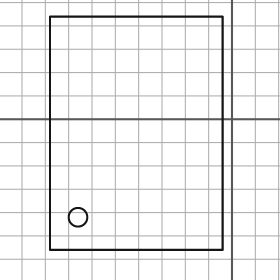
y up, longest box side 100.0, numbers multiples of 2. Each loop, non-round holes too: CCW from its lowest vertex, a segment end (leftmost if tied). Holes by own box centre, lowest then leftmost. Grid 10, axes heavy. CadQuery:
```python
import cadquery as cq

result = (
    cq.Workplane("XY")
    .moveTo(-78.0, -56.0)
    .lineTo(-4.0, -56.0)
    .lineTo(-4.0, 44.0)
    .lineTo(-78.0, 44.0)
    .close()
    .moveTo(-66.0, -42.0)
    .circle(4.0)
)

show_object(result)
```